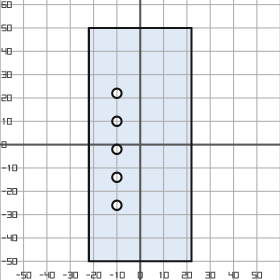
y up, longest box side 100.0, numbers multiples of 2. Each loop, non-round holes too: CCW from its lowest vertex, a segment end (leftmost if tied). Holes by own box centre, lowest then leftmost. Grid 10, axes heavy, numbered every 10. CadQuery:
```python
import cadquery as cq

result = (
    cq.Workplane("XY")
    .moveTo(-22.0, -50.0)
    .lineTo(22.0, -50.0)
    .lineTo(22.0, 50.0)
    .lineTo(-22.0, 50.0)
    .close()
    .moveTo(-10.0, -26.0)
    .circle(2.0)
    .moveTo(-10.0, -14.0)
    .circle(2.0)
    .moveTo(-10.0, -2.0)
    .circle(2.0)
    .moveTo(-10.0, 10.0)
    .circle(2.0)
    .moveTo(-10.0, 22.0)
    .circle(2.0)
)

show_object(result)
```